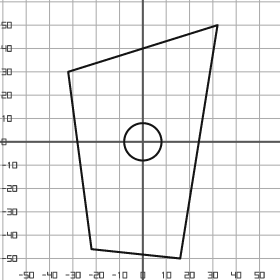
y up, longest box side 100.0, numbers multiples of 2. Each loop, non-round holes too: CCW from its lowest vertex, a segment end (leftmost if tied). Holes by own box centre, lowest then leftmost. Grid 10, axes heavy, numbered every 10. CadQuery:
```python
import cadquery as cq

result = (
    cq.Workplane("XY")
    .moveTo(16.0, -50.0)
    .lineTo(32.0, 50.0)
    .lineTo(-32.0, 30.0)
    .lineTo(-22.0, -46.0)
    .close()
    .moveTo(0.0, 0.0)
    .circle(8.0)
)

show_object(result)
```